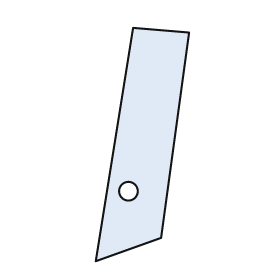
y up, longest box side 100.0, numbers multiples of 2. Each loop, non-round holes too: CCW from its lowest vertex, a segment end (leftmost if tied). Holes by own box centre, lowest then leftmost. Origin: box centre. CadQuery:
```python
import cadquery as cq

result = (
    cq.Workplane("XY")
    .moveTo(-20.0, -50.0)
    .lineTo(8.0, -40.0)
    .lineTo(20.0, 48.0)
    .lineTo(-4.0, 50.0)
    .close()
    .moveTo(-6.0, -20.0)
    .circle(4.0)
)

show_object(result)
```